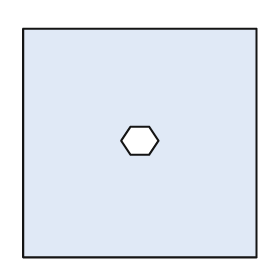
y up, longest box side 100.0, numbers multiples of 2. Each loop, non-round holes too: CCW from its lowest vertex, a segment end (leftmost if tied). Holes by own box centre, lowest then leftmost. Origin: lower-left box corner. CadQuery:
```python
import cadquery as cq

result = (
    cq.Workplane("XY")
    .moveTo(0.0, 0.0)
    .lineTo(100.0, 0.0)
    .lineTo(100.0, 98.0)
    .lineTo(0.0, 98.0)
    .close()
    .moveTo(46.0, 44.0)
    .lineTo(54.0, 44.0)
    .lineTo(58.0, 50.0)
    .lineTo(54.0, 56.0)
    .lineTo(46.0, 56.0)
    .lineTo(42.0, 50.0)
    .close()
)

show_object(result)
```